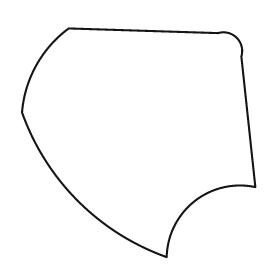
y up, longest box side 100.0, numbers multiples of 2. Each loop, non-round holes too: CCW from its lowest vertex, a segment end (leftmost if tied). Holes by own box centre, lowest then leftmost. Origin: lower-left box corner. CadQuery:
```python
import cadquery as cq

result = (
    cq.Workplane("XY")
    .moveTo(62.0, 0.0)
    .threePointArc((74.0, 24.0), (100.0, 30.0))
    .lineTo(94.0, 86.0)
    .threePointArc((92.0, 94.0), (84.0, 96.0))
    .lineTo(20.0, 98.0)
    .threePointArc((6.0, 82.0), (0.0, 62.0))
    .threePointArc((24.0, 24.0), (62.0, 0.0))
    .close()
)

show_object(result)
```